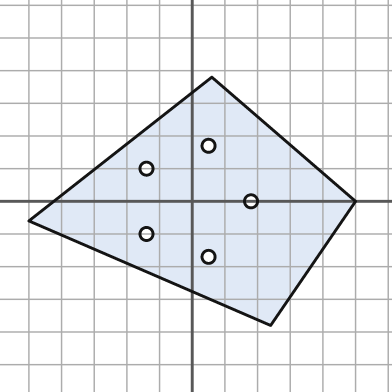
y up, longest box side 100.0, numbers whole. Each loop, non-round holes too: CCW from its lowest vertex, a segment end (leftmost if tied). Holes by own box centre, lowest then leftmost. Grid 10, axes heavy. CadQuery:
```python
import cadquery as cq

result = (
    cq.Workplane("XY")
    .moveTo(24.0, -38.0)
    .lineTo(50.0, 0.0)
    .lineTo(6.0, 38.0)
    .lineTo(-50.0, -6.0)
    .close()
    .moveTo(5.0, -17.0)
    .circle(2.0)
    .moveTo(-14.0, -10.0)
    .circle(2.0)
    .moveTo(18.0, 0.0)
    .circle(2.0)
    .moveTo(-14.0, 10.0)
    .circle(2.0)
    .moveTo(5.0, 17.0)
    .circle(2.0)
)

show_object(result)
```